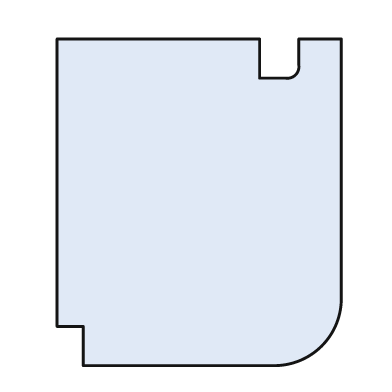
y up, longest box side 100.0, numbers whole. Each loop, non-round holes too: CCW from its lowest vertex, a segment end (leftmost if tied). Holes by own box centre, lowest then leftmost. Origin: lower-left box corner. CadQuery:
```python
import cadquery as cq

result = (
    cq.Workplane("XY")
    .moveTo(8.0, 0.0)
    .lineTo(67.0, 0.0)
    .threePointArc((81.0, 6.0), (87.0, 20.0))
    .lineTo(87.0, 100.0)
    .lineTo(74.0, 100.0)
    .lineTo(74.0, 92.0)
    .threePointArc((73.0, 89.0), (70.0, 88.0))
    .lineTo(62.0, 88.0)
    .lineTo(62.0, 100.0)
    .lineTo(0.0, 100.0)
    .lineTo(0.0, 12.0)
    .lineTo(8.0, 12.0)
    .close()
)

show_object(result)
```